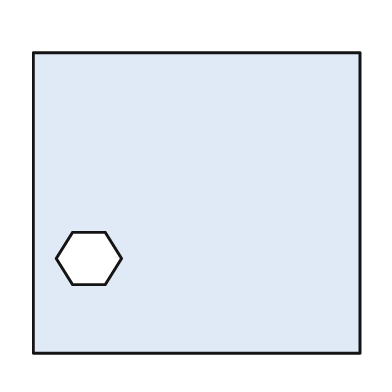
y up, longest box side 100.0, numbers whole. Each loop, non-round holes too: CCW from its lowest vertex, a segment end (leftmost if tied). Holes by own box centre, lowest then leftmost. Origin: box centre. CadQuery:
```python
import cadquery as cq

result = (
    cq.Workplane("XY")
    .moveTo(-50.0, -46.0)
    .lineTo(50.0, -46.0)
    .lineTo(50.0, 46.0)
    .lineTo(-50.0, 46.0)
    .close()
    .moveTo(-38.0, -25.0)
    .lineTo(-28.0, -25.0)
    .lineTo(-23.0, -17.0)
    .lineTo(-28.0, -9.0)
    .lineTo(-38.0, -9.0)
    .lineTo(-43.0, -17.0)
    .close()
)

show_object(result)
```